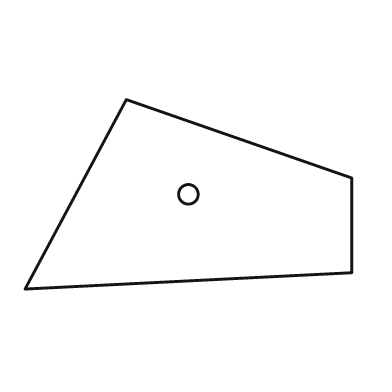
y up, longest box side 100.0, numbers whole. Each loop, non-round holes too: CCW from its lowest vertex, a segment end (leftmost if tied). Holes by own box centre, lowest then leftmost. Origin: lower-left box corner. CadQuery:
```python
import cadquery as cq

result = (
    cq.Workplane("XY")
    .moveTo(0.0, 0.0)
    .lineTo(100.0, 5.0)
    .lineTo(100.0, 34.0)
    .lineTo(31.0, 58.0)
    .close()
    .moveTo(50.0, 29.0)
    .circle(3.0)
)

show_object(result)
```